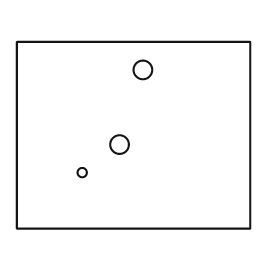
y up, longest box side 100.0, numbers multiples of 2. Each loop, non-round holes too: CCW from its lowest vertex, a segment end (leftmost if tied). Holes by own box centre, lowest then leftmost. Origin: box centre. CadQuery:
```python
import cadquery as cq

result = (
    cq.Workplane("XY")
    .moveTo(-50.0, -40.0)
    .lineTo(50.0, -40.0)
    .lineTo(50.0, 40.0)
    .lineTo(-50.0, 40.0)
    .close()
    .moveTo(-22.0, -16.0)
    .circle(2.0)
    .moveTo(-6.0, -4.0)
    .circle(4.0)
    .moveTo(4.0, 28.0)
    .circle(4.0)
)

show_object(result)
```